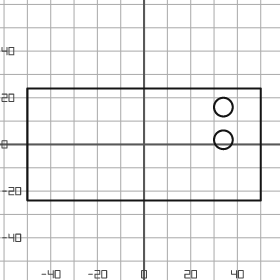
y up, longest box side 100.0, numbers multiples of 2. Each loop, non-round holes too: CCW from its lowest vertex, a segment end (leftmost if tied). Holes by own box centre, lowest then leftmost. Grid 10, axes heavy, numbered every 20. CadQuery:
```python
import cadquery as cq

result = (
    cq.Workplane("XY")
    .moveTo(-50.0, -24.0)
    .lineTo(50.0, -24.0)
    .lineTo(50.0, 24.0)
    .lineTo(-50.0, 24.0)
    .close()
    .moveTo(34.0, 2.0)
    .circle(4.0)
    .moveTo(34.0, 16.0)
    .circle(4.0)
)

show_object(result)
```